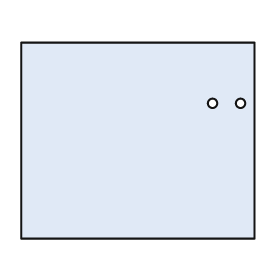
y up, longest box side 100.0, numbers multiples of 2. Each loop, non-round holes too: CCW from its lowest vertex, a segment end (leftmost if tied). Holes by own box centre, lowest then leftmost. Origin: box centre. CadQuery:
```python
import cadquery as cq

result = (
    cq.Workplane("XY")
    .moveTo(-50.0, -42.0)
    .lineTo(50.0, -42.0)
    .lineTo(50.0, 42.0)
    .lineTo(-50.0, 42.0)
    .close()
    .moveTo(32.0, 16.0)
    .circle(2.0)
    .moveTo(44.0, 16.0)
    .circle(2.0)
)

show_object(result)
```